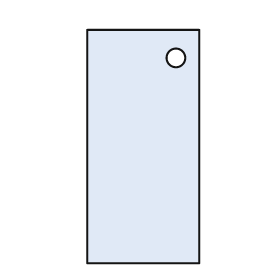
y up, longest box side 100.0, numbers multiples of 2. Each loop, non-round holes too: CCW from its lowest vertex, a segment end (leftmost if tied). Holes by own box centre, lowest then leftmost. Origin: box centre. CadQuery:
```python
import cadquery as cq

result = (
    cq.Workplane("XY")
    .moveTo(-24.0, -50.0)
    .lineTo(24.0, -50.0)
    .lineTo(24.0, 50.0)
    .lineTo(-24.0, 50.0)
    .close()
    .moveTo(14.0, 38.0)
    .circle(4.0)
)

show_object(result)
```